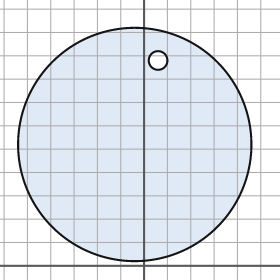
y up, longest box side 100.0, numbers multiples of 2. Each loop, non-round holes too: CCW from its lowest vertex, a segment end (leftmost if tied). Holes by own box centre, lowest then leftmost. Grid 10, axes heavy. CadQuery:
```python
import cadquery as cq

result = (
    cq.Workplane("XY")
    .moveTo(-4.0, 52.0)
    .circle(50.0)
    .moveTo(6.0, 88.0)
    .circle(4.0)
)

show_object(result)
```